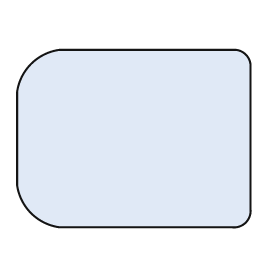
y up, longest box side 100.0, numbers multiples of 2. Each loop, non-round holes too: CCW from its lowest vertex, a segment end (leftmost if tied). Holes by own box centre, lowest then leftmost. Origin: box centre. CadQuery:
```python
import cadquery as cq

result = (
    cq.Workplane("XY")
    .moveTo(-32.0, -38.0)
    .lineTo(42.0, -38.0)
    .threePointArc((48.0, -36.0), (50.0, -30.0))
    .lineTo(50.0, 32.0)
    .threePointArc((48.0, 36.0), (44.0, 38.0))
    .lineTo(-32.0, 38.0)
    .threePointArc((-44.0, 32.0), (-50.0, 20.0))
    .lineTo(-50.0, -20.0)
    .threePointArc((-44.0, -32.0), (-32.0, -38.0))
    .close()
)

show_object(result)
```